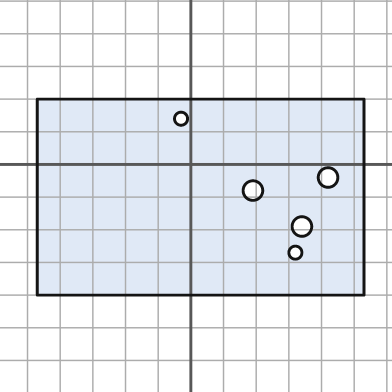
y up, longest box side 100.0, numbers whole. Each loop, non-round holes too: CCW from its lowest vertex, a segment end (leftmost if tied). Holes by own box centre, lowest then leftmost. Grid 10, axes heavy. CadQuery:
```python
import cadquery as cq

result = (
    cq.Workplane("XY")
    .moveTo(-47.0, -40.0)
    .lineTo(53.0, -40.0)
    .lineTo(53.0, 20.0)
    .lineTo(-47.0, 20.0)
    .close()
    .moveTo(32.0, -27.0)
    .circle(2.0)
    .moveTo(34.0, -19.0)
    .circle(3.0)
    .moveTo(19.0, -8.0)
    .circle(3.0)
    .moveTo(42.0, -4.0)
    .circle(3.0)
    .moveTo(-3.0, 14.0)
    .circle(2.0)
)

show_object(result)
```